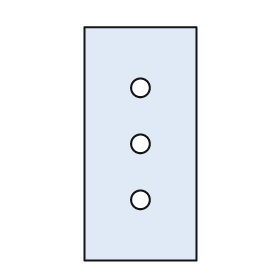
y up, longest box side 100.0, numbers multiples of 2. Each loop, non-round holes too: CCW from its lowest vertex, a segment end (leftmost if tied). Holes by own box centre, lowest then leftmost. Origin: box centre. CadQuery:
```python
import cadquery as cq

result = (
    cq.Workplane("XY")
    .moveTo(-24.0, -50.0)
    .lineTo(24.0, -50.0)
    .lineTo(24.0, 50.0)
    .lineTo(-24.0, 50.0)
    .close()
    .moveTo(0.0, -24.0)
    .circle(4.0)
    .moveTo(0.0, 0.0)
    .circle(4.0)
    .moveTo(0.0, 24.0)
    .circle(4.0)
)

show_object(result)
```